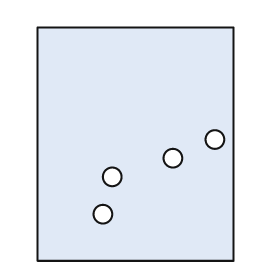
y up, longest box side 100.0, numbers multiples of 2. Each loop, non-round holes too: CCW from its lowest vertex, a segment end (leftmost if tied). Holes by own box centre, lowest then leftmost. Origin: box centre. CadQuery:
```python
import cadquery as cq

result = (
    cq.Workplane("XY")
    .moveTo(-42.0, -50.0)
    .lineTo(42.0, -50.0)
    .lineTo(42.0, 50.0)
    .lineTo(-42.0, 50.0)
    .close()
    .moveTo(-14.0, -30.0)
    .circle(4.0)
    .moveTo(-10.0, -14.0)
    .circle(4.0)
    .moveTo(16.0, -6.0)
    .circle(4.0)
    .moveTo(34.0, 2.0)
    .circle(4.0)
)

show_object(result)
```